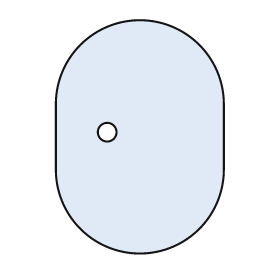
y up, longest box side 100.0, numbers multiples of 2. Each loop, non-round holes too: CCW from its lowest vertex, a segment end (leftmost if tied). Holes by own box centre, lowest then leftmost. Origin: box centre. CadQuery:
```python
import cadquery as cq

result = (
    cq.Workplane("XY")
    .moveTo(-36.0, -14.0)
    .threePointArc((0.0, -50.0), (36.0, -14.0))
    .lineTo(36.0, 14.0)
    .threePointArc((0.0, 50.0), (-36.0, 14.0))
    .close()
    .moveTo(-14.0, 2.0)
    .circle(4.0)
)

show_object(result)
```